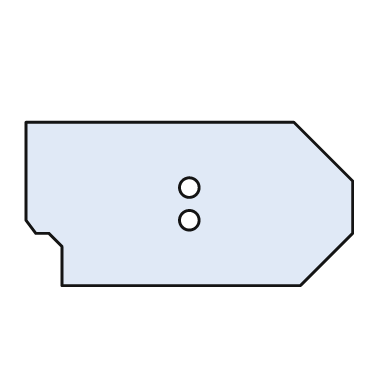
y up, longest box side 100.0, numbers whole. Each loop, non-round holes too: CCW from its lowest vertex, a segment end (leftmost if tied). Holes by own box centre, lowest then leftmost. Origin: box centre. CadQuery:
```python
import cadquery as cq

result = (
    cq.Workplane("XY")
    .moveTo(-39.0, -25.0)
    .lineTo(34.0, -25.0)
    .lineTo(50.0, -9.0)
    .lineTo(50.0, 7.0)
    .lineTo(32.0, 25.0)
    .lineTo(-50.0, 25.0)
    .lineTo(-50.0, -5.0)
    .lineTo(-47.0, -9.0)
    .lineTo(-43.0, -9.0)
    .lineTo(-39.0, -13.0)
    .close()
    .moveTo(0.0, -5.0)
    .circle(3.0)
    .moveTo(0.0, 5.0)
    .circle(3.0)
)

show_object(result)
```